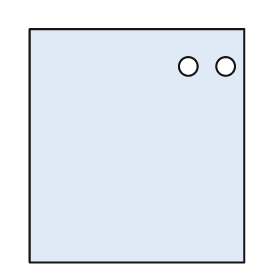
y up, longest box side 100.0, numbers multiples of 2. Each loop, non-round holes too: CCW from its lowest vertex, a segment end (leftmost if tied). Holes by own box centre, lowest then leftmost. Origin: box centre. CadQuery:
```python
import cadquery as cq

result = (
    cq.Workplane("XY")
    .moveTo(-46.0, -50.0)
    .lineTo(46.0, -50.0)
    .lineTo(46.0, 50.0)
    .lineTo(-46.0, 50.0)
    .close()
    .moveTo(22.0, 34.0)
    .circle(4.0)
    .moveTo(38.0, 34.0)
    .circle(4.0)
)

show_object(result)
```